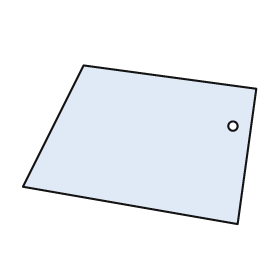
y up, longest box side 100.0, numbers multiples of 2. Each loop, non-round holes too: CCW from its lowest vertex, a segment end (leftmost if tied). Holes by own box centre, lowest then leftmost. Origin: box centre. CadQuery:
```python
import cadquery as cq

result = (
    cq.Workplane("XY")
    .moveTo(42.0, -34.0)
    .lineTo(50.0, 24.0)
    .lineTo(-24.0, 34.0)
    .lineTo(-50.0, -18.0)
    .close()
    .moveTo(40.0, 8.0)
    .circle(2.0)
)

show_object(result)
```